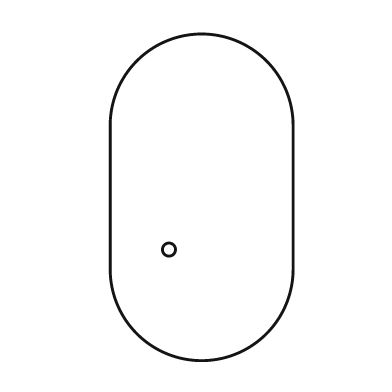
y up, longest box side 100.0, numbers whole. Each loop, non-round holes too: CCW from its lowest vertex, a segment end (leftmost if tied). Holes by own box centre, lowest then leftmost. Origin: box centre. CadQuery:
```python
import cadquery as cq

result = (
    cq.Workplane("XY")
    .moveTo(-28.0, -22.0)
    .threePointArc((0.0, -50.0), (28.0, -22.0))
    .lineTo(28.0, 22.0)
    .threePointArc((0.0, 50.0), (-28.0, 22.0))
    .close()
    .moveTo(-10.0, -16.0)
    .circle(2.0)
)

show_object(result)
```